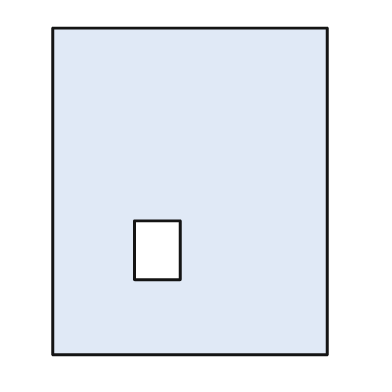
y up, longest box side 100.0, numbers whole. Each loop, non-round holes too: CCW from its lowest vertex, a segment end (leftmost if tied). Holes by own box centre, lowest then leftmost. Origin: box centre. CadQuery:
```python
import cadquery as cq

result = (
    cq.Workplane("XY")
    .moveTo(-42.0, -50.0)
    .lineTo(42.0, -50.0)
    .lineTo(42.0, 50.0)
    .lineTo(-42.0, 50.0)
    .close()
    .moveTo(-17.0, -27.0)
    .lineTo(-3.0, -27.0)
    .lineTo(-3.0, -9.0)
    .lineTo(-17.0, -9.0)
    .close()
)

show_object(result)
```